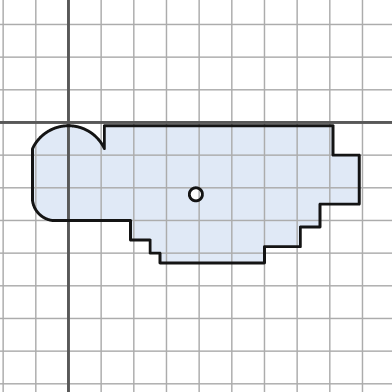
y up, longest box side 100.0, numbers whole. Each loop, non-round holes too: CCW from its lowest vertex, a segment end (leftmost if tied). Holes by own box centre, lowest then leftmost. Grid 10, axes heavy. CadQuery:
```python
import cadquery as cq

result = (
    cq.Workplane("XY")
    .moveTo(28.0, -43.0)
    .lineTo(60.0, -43.0)
    .lineTo(60.0, -38.0)
    .lineTo(71.0, -38.0)
    .lineTo(71.0, -32.0)
    .lineTo(77.0, -32.0)
    .lineTo(77.0, -25.0)
    .lineTo(89.0, -25.0)
    .lineTo(89.0, -10.0)
    .lineTo(81.0, -10.0)
    .lineTo(81.0, -1.0)
    .lineTo(11.0, -1.0)
    .lineTo(11.0, -8.0)
    .threePointArc((0.0, -1.0), (-11.0, -8.0))
    .lineTo(-11.0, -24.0)
    .threePointArc((-9.0, -28.0), (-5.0, -30.0))
    .lineTo(19.0, -30.0)
    .lineTo(19.0, -36.0)
    .lineTo(25.0, -36.0)
    .lineTo(25.0, -40.0)
    .lineTo(28.0, -40.0)
    .close()
    .moveTo(39.0, -22.0)
    .circle(2.0)
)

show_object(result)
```